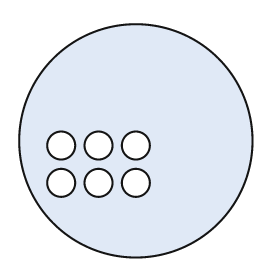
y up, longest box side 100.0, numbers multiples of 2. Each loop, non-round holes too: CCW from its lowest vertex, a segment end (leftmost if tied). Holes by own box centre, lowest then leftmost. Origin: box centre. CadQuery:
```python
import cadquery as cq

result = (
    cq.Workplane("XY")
    .moveTo(0.0, 0.0)
    .circle(50.0)
    .moveTo(-32.0, -18.0)
    .circle(6.0)
    .moveTo(-16.0, -18.0)
    .circle(6.0)
    .moveTo(0.0, -18.0)
    .circle(6.0)
    .moveTo(-32.0, -2.0)
    .circle(6.0)
    .moveTo(-16.0, -2.0)
    .circle(6.0)
    .moveTo(0.0, -2.0)
    .circle(6.0)
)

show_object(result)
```